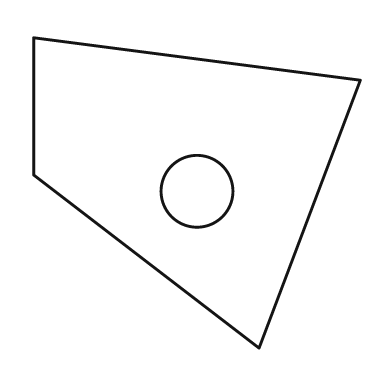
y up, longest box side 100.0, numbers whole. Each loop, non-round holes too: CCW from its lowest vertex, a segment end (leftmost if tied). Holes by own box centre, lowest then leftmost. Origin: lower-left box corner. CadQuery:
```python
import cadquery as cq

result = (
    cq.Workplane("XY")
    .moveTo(69.0, 0.0)
    .lineTo(100.0, 82.0)
    .lineTo(0.0, 95.0)
    .lineTo(0.0, 53.0)
    .close()
    .moveTo(50.0, 48.0)
    .circle(11.0)
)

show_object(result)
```